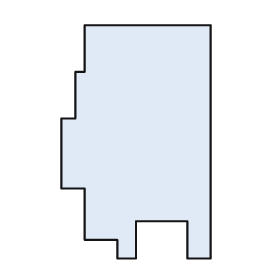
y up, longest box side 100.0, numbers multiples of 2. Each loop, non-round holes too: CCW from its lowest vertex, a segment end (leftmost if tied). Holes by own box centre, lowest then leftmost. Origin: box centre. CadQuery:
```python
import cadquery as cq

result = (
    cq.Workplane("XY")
    .moveTo(-8.0, -50.0)
    .lineTo(0.0, -50.0)
    .lineTo(0.0, -34.0)
    .lineTo(22.0, -34.0)
    .lineTo(22.0, -50.0)
    .lineTo(32.0, -50.0)
    .lineTo(32.0, 50.0)
    .lineTo(-22.0, 50.0)
    .lineTo(-22.0, 30.0)
    .lineTo(-26.0, 30.0)
    .lineTo(-26.0, 10.0)
    .lineTo(-32.0, 10.0)
    .lineTo(-32.0, -20.0)
    .lineTo(-22.0, -20.0)
    .lineTo(-22.0, -42.0)
    .lineTo(-8.0, -42.0)
    .close()
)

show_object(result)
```